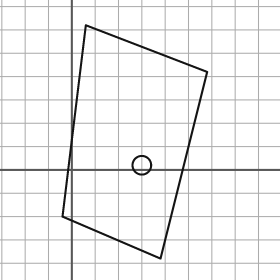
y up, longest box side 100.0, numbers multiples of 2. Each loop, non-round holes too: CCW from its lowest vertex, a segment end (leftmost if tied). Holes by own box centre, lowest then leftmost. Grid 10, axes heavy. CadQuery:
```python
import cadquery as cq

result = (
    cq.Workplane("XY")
    .moveTo(38.0, -38.0)
    .lineTo(58.0, 42.0)
    .lineTo(6.0, 62.0)
    .lineTo(-4.0, -20.0)
    .close()
    .moveTo(30.0, 2.0)
    .circle(4.0)
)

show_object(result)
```